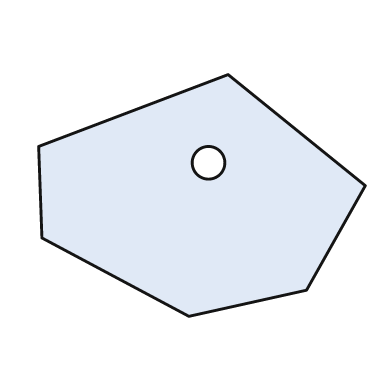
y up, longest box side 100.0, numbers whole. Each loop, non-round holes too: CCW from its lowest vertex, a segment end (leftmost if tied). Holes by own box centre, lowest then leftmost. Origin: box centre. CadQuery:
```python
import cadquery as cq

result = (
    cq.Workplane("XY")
    .moveTo(-4.0, -37.0)
    .lineTo(32.0, -29.0)
    .lineTo(50.0, 3.0)
    .lineTo(8.0, 37.0)
    .lineTo(-50.0, 15.0)
    .lineTo(-49.0, -13.0)
    .close()
    .moveTo(2.0, 10.0)
    .circle(5.0)
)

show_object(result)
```